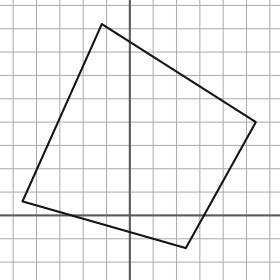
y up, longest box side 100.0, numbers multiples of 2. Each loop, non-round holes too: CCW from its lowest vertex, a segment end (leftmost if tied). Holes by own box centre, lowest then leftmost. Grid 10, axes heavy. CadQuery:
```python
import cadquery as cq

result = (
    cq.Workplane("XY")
    .moveTo(24.0, -14.0)
    .lineTo(54.0, 40.0)
    .lineTo(-12.0, 82.0)
    .lineTo(-46.0, 6.0)
    .close()
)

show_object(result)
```